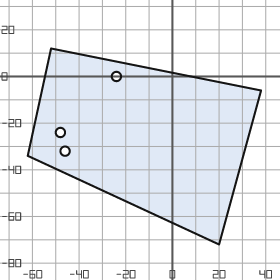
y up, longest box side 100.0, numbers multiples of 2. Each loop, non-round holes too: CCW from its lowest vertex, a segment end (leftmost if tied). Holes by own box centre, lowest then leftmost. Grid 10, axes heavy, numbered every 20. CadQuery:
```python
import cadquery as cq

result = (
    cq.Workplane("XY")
    .moveTo(20.0, -72.0)
    .lineTo(38.0, -6.0)
    .lineTo(-52.0, 12.0)
    .lineTo(-62.0, -34.0)
    .close()
    .moveTo(-46.0, -32.0)
    .circle(2.0)
    .moveTo(-48.0, -24.0)
    .circle(2.0)
    .moveTo(-24.0, 0.0)
    .circle(2.0)
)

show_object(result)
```